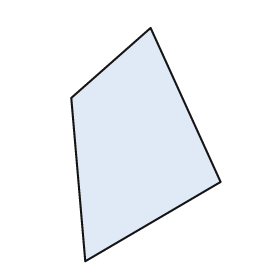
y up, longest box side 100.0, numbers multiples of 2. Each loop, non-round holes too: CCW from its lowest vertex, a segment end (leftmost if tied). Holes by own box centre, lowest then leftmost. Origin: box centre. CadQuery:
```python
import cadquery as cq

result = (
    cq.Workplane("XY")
    .moveTo(-26.0, -50.0)
    .lineTo(32.0, -16.0)
    .lineTo(2.0, 50.0)
    .lineTo(-32.0, 20.0)
    .close()
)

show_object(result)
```